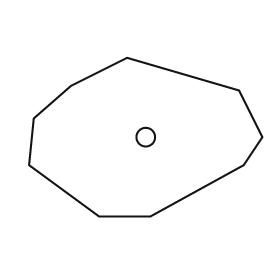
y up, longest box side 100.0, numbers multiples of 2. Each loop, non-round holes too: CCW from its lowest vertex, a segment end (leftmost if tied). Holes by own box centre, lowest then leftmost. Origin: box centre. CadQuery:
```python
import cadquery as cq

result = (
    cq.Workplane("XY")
    .moveTo(-20.0, -34.0)
    .lineTo(2.0, -34.0)
    .lineTo(42.0, -12.0)
    .lineTo(50.0, 0.0)
    .lineTo(40.0, 20.0)
    .lineTo(-8.0, 34.0)
    .lineTo(-32.0, 22.0)
    .lineTo(-48.0, 8.0)
    .lineTo(-50.0, -12.0)
    .close()
    .moveTo(0.0, 0.0)
    .circle(4.0)
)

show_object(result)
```